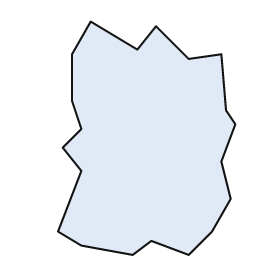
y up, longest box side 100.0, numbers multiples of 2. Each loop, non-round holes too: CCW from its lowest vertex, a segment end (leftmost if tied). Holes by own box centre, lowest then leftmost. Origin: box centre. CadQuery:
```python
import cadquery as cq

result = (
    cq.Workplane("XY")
    .moveTo(-6.0, -50.0)
    .lineTo(2.0, -44.0)
    .lineTo(18.0, -50.0)
    .lineTo(28.0, -40.0)
    .lineTo(36.0, -26.0)
    .lineTo(32.0, -10.0)
    .lineTo(38.0, 6.0)
    .lineTo(34.0, 12.0)
    .lineTo(32.0, 36.0)
    .lineTo(18.0, 34.0)
    .lineTo(4.0, 48.0)
    .lineTo(-4.0, 38.0)
    .lineTo(-24.0, 50.0)
    .lineTo(-32.0, 36.0)
    .lineTo(-32.0, 16.0)
    .lineTo(-28.0, 4.0)
    .lineTo(-36.0, -4.0)
    .lineTo(-28.0, -14.0)
    .lineTo(-38.0, -40.0)
    .lineTo(-28.0, -46.0)
    .close()
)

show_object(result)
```